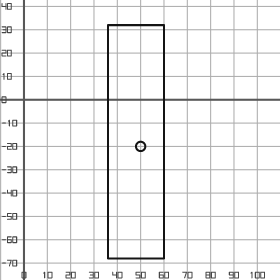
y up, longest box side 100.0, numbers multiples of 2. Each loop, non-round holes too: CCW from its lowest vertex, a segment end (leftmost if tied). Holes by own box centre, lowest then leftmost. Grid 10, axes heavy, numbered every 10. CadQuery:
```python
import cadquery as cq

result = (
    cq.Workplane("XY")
    .moveTo(36.0, -68.0)
    .lineTo(60.0, -68.0)
    .lineTo(60.0, 32.0)
    .lineTo(36.0, 32.0)
    .close()
    .moveTo(50.0, -20.0)
    .circle(2.0)
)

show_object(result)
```